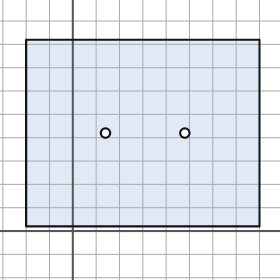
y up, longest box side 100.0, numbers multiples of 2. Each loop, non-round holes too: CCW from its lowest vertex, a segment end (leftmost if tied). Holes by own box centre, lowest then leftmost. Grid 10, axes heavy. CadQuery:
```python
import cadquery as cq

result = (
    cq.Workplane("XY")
    .moveTo(-20.0, 2.0)
    .lineTo(80.0, 2.0)
    .lineTo(80.0, 82.0)
    .lineTo(-20.0, 82.0)
    .close()
    .moveTo(14.0, 42.0)
    .circle(2.0)
    .moveTo(48.0, 42.0)
    .circle(2.0)
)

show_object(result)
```